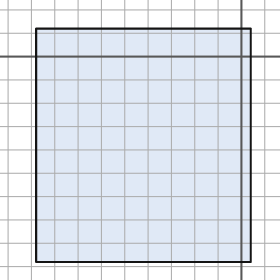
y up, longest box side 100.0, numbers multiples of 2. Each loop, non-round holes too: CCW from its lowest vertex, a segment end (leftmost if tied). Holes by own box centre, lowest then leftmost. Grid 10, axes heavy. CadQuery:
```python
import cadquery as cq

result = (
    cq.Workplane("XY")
    .moveTo(-88.0, -88.0)
    .lineTo(4.0, -88.0)
    .lineTo(4.0, 12.0)
    .lineTo(-88.0, 12.0)
    .close()
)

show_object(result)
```